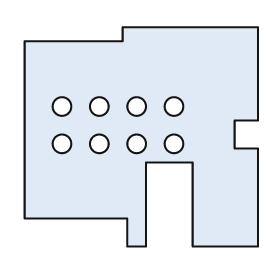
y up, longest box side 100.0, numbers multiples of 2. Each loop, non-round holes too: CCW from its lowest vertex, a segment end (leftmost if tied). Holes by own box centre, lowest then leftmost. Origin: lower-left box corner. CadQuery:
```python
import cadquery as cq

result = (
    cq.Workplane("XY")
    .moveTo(44.0, 0.0)
    .lineTo(52.0, 0.0)
    .lineTo(52.0, 36.0)
    .lineTo(72.0, 36.0)
    .lineTo(72.0, 0.0)
    .lineTo(100.0, 0.0)
    .lineTo(100.0, 42.0)
    .lineTo(90.0, 42.0)
    .lineTo(90.0, 54.0)
    .lineTo(100.0, 54.0)
    .lineTo(100.0, 94.0)
    .lineTo(42.0, 94.0)
    .lineTo(42.0, 88.0)
    .lineTo(0.0, 88.0)
    .lineTo(0.0, 12.0)
    .lineTo(44.0, 12.0)
    .close()
    .moveTo(16.0, 44.0)
    .circle(4.0)
    .moveTo(32.0, 44.0)
    .circle(4.0)
    .moveTo(48.0, 44.0)
    .circle(4.0)
    .moveTo(64.0, 44.0)
    .circle(4.0)
    .moveTo(16.0, 60.0)
    .circle(4.0)
    .moveTo(32.0, 60.0)
    .circle(4.0)
    .moveTo(48.0, 60.0)
    .circle(4.0)
    .moveTo(64.0, 60.0)
    .circle(4.0)
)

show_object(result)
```